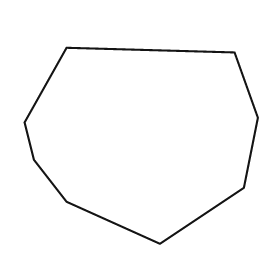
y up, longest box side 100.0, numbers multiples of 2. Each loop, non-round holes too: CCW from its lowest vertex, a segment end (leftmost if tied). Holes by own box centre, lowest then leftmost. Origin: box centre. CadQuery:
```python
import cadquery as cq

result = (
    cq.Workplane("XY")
    .moveTo(8.0, -42.0)
    .lineTo(44.0, -18.0)
    .lineTo(50.0, 12.0)
    .lineTo(40.0, 40.0)
    .lineTo(-32.0, 42.0)
    .lineTo(-50.0, 10.0)
    .lineTo(-46.0, -6.0)
    .lineTo(-32.0, -24.0)
    .close()
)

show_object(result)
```